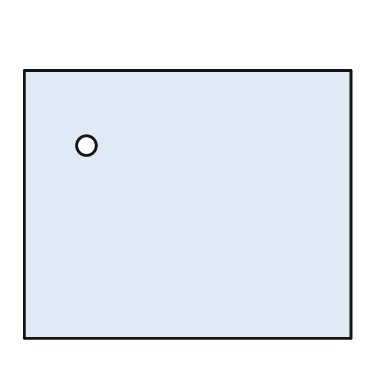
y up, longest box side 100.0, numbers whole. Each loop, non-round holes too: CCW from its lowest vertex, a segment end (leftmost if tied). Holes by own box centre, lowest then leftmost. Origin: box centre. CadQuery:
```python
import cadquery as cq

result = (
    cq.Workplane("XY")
    .moveTo(-50.0, -41.0)
    .lineTo(50.0, -41.0)
    .lineTo(50.0, 41.0)
    .lineTo(-50.0, 41.0)
    .close()
    .moveTo(-31.0, 18.0)
    .circle(3.0)
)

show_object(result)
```